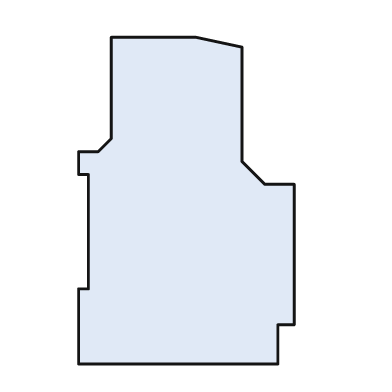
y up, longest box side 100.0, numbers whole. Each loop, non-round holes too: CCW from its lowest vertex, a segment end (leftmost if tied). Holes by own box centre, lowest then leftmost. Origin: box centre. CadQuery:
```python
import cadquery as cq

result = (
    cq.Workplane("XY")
    .moveTo(-33.0, -50.0)
    .lineTo(28.0, -50.0)
    .lineTo(28.0, -38.0)
    .lineTo(33.0, -38.0)
    .lineTo(33.0, 5.0)
    .lineTo(24.0, 5.0)
    .lineTo(17.0, 12.0)
    .lineTo(17.0, 47.0)
    .lineTo(3.0, 50.0)
    .lineTo(-23.0, 50.0)
    .lineTo(-23.0, 19.0)
    .lineTo(-27.0, 15.0)
    .lineTo(-33.0, 15.0)
    .lineTo(-33.0, 8.0)
    .lineTo(-30.0, 8.0)
    .lineTo(-30.0, -27.0)
    .lineTo(-33.0, -27.0)
    .close()
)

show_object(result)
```